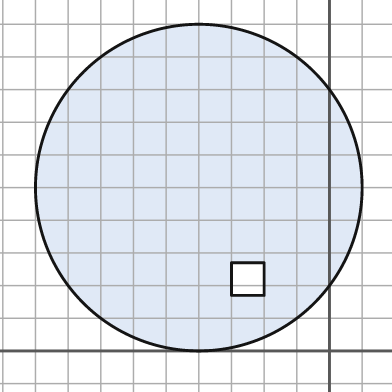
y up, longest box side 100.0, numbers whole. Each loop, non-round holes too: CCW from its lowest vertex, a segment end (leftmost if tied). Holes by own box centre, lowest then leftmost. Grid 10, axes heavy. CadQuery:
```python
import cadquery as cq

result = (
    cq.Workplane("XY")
    .moveTo(-40.0, 50.0)
    .circle(50.0)
    .moveTo(-30.0, 17.0)
    .lineTo(-20.0, 17.0)
    .lineTo(-20.0, 27.0)
    .lineTo(-30.0, 27.0)
    .close()
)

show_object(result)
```